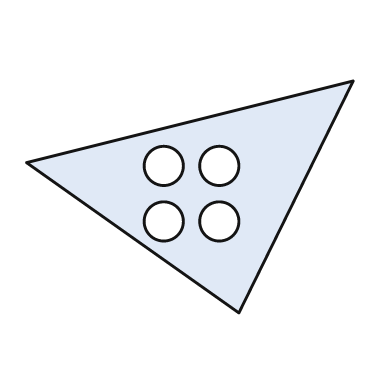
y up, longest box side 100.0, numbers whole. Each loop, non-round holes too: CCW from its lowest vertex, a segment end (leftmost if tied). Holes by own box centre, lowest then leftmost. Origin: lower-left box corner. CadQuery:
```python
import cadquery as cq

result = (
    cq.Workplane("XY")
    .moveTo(65.0, 0.0)
    .lineTo(100.0, 71.0)
    .lineTo(0.0, 46.0)
    .close()
    .moveTo(42.0, 28.0)
    .circle(6.0)
    .moveTo(59.0, 28.0)
    .circle(6.0)
    .moveTo(42.0, 45.0)
    .circle(6.0)
    .moveTo(59.0, 45.0)
    .circle(6.0)
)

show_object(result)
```